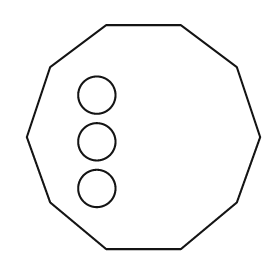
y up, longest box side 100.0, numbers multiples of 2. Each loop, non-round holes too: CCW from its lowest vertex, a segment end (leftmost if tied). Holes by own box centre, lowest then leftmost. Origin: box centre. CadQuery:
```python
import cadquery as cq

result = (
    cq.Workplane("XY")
    .moveTo(-16.0, -48.0)
    .lineTo(16.0, -48.0)
    .lineTo(40.0, -28.0)
    .lineTo(50.0, 0.0)
    .lineTo(40.0, 30.0)
    .lineTo(16.0, 48.0)
    .lineTo(-16.0, 48.0)
    .lineTo(-40.0, 30.0)
    .lineTo(-50.0, 0.0)
    .lineTo(-40.0, -28.0)
    .close()
    .moveTo(-20.0, -22.0)
    .circle(8.0)
    .moveTo(-20.0, -2.0)
    .circle(8.0)
    .moveTo(-20.0, 18.0)
    .circle(8.0)
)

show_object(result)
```